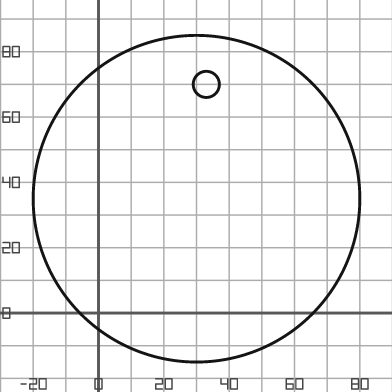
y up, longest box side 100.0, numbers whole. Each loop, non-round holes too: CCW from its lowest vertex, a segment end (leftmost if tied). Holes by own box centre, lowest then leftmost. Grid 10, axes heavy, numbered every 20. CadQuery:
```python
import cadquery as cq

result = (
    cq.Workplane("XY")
    .moveTo(30.0, 35.0)
    .circle(50.0)
    .moveTo(33.0, 70.0)
    .circle(4.0)
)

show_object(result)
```